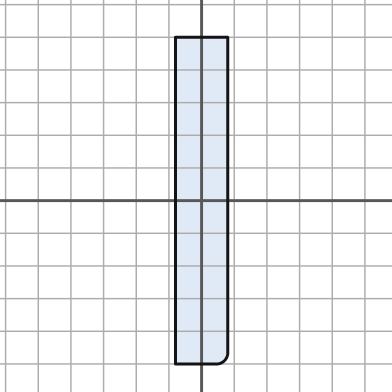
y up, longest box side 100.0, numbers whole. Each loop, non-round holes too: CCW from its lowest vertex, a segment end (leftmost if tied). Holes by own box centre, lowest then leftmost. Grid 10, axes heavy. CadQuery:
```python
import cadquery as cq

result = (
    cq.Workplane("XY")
    .moveTo(-8.0, -50.0)
    .lineTo(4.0, -50.0)
    .threePointArc((7.0, -49.0), (8.0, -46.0))
    .lineTo(8.0, 50.0)
    .lineTo(-8.0, 50.0)
    .close()
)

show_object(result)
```